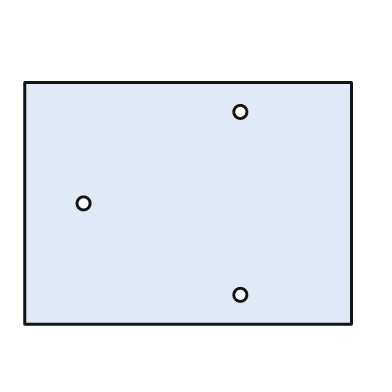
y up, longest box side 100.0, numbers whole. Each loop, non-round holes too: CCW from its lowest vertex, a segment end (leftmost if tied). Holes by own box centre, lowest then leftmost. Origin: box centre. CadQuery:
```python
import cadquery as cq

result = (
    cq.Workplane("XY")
    .moveTo(-50.0, -37.0)
    .lineTo(50.0, -37.0)
    .lineTo(50.0, 37.0)
    .lineTo(-50.0, 37.0)
    .close()
    .moveTo(16.0, -28.0)
    .circle(2.0)
    .moveTo(-32.0, 0.0)
    .circle(2.0)
    .moveTo(16.0, 28.0)
    .circle(2.0)
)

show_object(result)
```